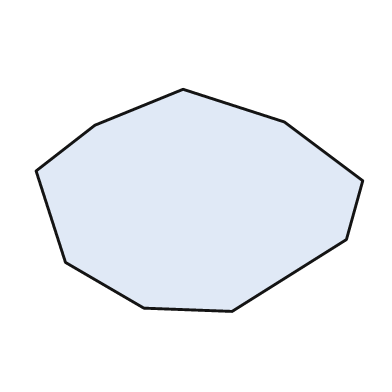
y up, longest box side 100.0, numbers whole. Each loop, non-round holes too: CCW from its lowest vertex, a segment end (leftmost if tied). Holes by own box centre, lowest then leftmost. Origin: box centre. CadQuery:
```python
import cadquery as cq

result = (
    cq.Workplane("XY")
    .moveTo(10.0, -34.0)
    .lineTo(45.0, -12.0)
    .lineTo(50.0, 6.0)
    .lineTo(26.0, 24.0)
    .lineTo(-5.0, 34.0)
    .lineTo(-32.0, 23.0)
    .lineTo(-50.0, 9.0)
    .lineTo(-41.0, -19.0)
    .lineTo(-17.0, -33.0)
    .close()
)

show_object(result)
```